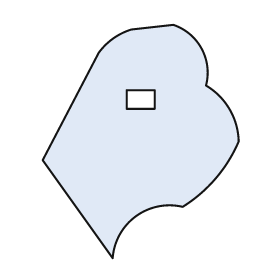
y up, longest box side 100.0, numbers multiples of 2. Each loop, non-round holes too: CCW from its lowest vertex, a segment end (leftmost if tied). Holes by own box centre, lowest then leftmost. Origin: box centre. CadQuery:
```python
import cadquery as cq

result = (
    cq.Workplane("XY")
    .moveTo(-12.0, -50.0)
    .threePointArc((-2.0, -32.0), (18.0, -28.0))
    .threePointArc((32.0, -16.0), (42.0, 0.0))
    .threePointArc((38.0, 14.0), (28.0, 24.0))
    .threePointArc((26.0, 40.0), (14.0, 50.0))
    .lineTo(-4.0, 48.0)
    .threePointArc((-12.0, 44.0), (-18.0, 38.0))
    .lineTo(-42.0, -8.0)
    .close()
    .moveTo(-6.0, 14.0)
    .lineTo(6.0, 14.0)
    .lineTo(6.0, 22.0)
    .lineTo(-6.0, 22.0)
    .close()
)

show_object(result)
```